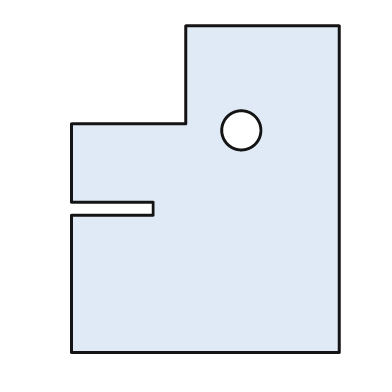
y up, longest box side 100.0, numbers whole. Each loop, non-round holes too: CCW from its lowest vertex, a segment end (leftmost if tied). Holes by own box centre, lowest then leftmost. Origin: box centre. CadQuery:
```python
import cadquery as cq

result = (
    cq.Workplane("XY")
    .moveTo(-41.0, -50.0)
    .lineTo(41.0, -50.0)
    .lineTo(41.0, 50.0)
    .lineTo(-6.0, 50.0)
    .lineTo(-6.0, 20.0)
    .lineTo(-41.0, 20.0)
    .lineTo(-41.0, -4.0)
    .lineTo(-16.0, -4.0)
    .lineTo(-16.0, -8.0)
    .lineTo(-41.0, -8.0)
    .close()
    .moveTo(11.0, 18.0)
    .circle(6.0)
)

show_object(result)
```